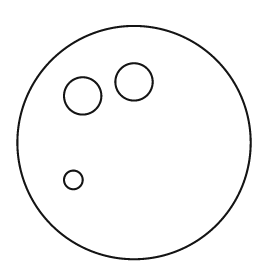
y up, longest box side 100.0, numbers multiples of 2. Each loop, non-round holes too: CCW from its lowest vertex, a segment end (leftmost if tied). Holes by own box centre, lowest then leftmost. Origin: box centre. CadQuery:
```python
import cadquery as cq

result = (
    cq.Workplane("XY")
    .moveTo(0.0, 0.0)
    .circle(50.0)
    .moveTo(-26.0, -16.0)
    .circle(4.0)
    .moveTo(-22.0, 20.0)
    .circle(8.0)
    .moveTo(0.0, 26.0)
    .circle(8.0)
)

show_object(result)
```